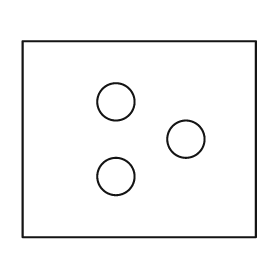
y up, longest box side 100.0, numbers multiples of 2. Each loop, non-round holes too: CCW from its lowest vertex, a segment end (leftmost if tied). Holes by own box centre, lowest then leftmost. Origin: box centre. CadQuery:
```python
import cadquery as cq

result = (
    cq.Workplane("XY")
    .moveTo(-50.0, -42.0)
    .lineTo(50.0, -42.0)
    .lineTo(50.0, 42.0)
    .lineTo(-50.0, 42.0)
    .close()
    .moveTo(-10.0, -16.0)
    .circle(8.0)
    .moveTo(20.0, 0.0)
    .circle(8.0)
    .moveTo(-10.0, 16.0)
    .circle(8.0)
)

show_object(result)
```